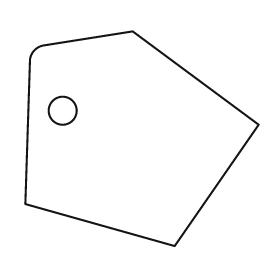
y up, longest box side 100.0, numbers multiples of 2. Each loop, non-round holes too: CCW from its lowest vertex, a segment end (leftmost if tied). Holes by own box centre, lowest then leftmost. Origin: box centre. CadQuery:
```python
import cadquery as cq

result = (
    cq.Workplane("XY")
    .moveTo(14.0, -46.0)
    .lineTo(50.0, 6.0)
    .lineTo(-4.0, 46.0)
    .lineTo(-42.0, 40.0)
    .threePointArc((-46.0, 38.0), (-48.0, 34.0))
    .lineTo(-50.0, -28.0)
    .close()
    .moveTo(-34.0, 12.0)
    .circle(6.0)
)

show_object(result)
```